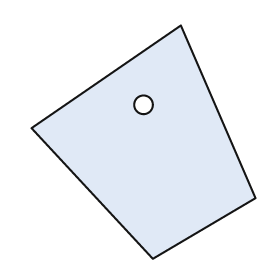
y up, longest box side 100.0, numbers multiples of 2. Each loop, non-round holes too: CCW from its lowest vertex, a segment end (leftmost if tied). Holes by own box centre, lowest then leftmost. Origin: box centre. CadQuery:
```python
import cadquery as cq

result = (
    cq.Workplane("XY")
    .moveTo(4.0, -50.0)
    .lineTo(48.0, -24.0)
    .lineTo(16.0, 50.0)
    .lineTo(-48.0, 6.0)
    .close()
    .moveTo(0.0, 16.0)
    .circle(4.0)
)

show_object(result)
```